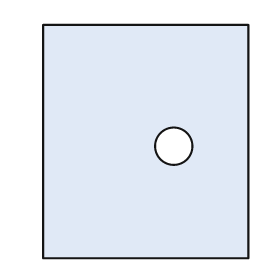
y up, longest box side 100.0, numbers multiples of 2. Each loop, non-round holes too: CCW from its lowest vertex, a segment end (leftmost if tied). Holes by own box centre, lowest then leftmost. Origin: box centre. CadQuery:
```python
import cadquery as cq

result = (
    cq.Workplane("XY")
    .moveTo(-44.0, -50.0)
    .lineTo(44.0, -50.0)
    .lineTo(44.0, 50.0)
    .lineTo(-44.0, 50.0)
    .close()
    .moveTo(12.0, -2.0)
    .circle(8.0)
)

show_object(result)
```